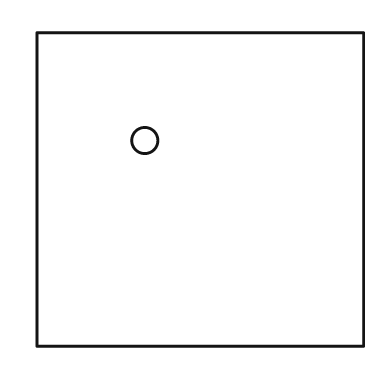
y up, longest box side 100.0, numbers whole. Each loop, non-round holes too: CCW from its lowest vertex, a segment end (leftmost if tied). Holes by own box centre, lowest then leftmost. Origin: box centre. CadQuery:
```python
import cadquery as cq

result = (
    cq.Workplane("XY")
    .moveTo(-50.0, -48.0)
    .lineTo(50.0, -48.0)
    .lineTo(50.0, 48.0)
    .lineTo(-50.0, 48.0)
    .close()
    .moveTo(-17.0, 15.0)
    .circle(4.0)
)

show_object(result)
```